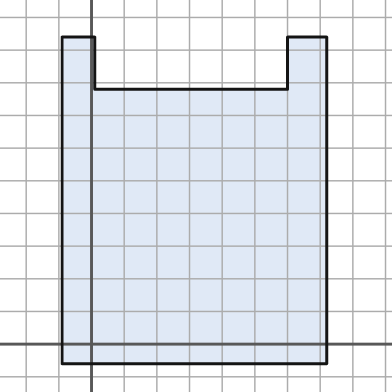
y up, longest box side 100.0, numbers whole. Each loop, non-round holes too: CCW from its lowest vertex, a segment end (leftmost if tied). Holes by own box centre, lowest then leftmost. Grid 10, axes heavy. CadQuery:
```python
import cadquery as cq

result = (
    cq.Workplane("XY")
    .moveTo(-9.0, -6.0)
    .lineTo(72.0, -6.0)
    .lineTo(72.0, 94.0)
    .lineTo(60.0, 94.0)
    .lineTo(60.0, 78.0)
    .lineTo(1.0, 78.0)
    .lineTo(1.0, 94.0)
    .lineTo(-9.0, 94.0)
    .close()
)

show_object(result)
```